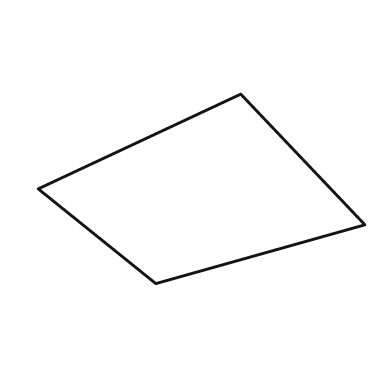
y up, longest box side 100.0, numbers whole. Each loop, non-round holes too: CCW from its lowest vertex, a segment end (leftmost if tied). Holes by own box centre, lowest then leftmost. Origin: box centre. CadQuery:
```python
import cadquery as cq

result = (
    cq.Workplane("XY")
    .moveTo(-14.0, -29.0)
    .lineTo(50.0, -11.0)
    .lineTo(12.0, 29.0)
    .lineTo(-50.0, 0.0)
    .close()
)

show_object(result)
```